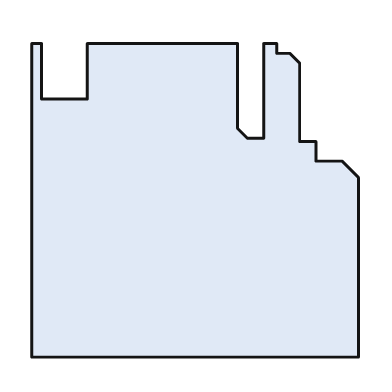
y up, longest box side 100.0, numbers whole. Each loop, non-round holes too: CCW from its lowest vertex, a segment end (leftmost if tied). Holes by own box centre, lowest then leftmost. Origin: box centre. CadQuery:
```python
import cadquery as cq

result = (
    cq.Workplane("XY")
    .moveTo(-50.0, -48.0)
    .lineTo(50.0, -48.0)
    .lineTo(50.0, 7.0)
    .lineTo(45.0, 12.0)
    .lineTo(37.0, 12.0)
    .lineTo(37.0, 18.0)
    .lineTo(32.0, 18.0)
    .lineTo(32.0, 42.0)
    .lineTo(29.0, 45.0)
    .lineTo(25.0, 45.0)
    .lineTo(25.0, 48.0)
    .lineTo(21.0, 48.0)
    .lineTo(21.0, 19.0)
    .lineTo(16.0, 19.0)
    .lineTo(13.0, 22.0)
    .lineTo(13.0, 48.0)
    .lineTo(-33.0, 48.0)
    .lineTo(-33.0, 31.0)
    .lineTo(-47.0, 31.0)
    .lineTo(-47.0, 48.0)
    .lineTo(-50.0, 48.0)
    .close()
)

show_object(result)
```